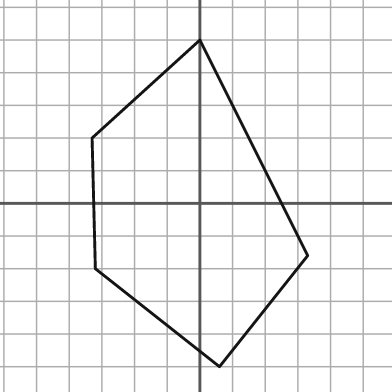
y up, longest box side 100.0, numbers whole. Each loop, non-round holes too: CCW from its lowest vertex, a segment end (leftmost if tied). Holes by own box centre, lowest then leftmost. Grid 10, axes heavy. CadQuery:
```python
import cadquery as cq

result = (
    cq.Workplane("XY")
    .moveTo(6.0, -50.0)
    .lineTo(33.0, -16.0)
    .lineTo(0.0, 50.0)
    .lineTo(-33.0, 20.0)
    .lineTo(-32.0, -20.0)
    .close()
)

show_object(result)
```